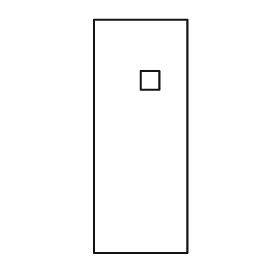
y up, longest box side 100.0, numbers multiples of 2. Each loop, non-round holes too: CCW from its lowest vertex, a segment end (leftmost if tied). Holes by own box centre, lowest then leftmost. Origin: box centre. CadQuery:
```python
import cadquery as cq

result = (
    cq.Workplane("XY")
    .moveTo(-20.0, -50.0)
    .lineTo(20.0, -50.0)
    .lineTo(20.0, 50.0)
    .lineTo(-20.0, 50.0)
    .close()
    .moveTo(0.0, 20.0)
    .lineTo(8.0, 20.0)
    .lineTo(8.0, 28.0)
    .lineTo(0.0, 28.0)
    .close()
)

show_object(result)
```